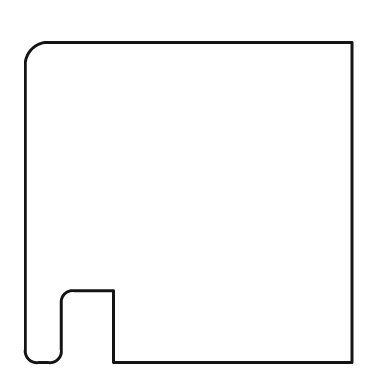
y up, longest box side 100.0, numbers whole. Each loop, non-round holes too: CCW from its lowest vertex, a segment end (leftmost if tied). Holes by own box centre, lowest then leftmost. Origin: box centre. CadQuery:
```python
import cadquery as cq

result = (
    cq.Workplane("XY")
    .moveTo(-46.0, -49.0)
    .lineTo(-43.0, -49.0)
    .threePointArc((-40.0, -48.0), (-39.0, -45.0))
    .lineTo(-39.0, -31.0)
    .threePointArc((-38.0, -28.0), (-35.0, -27.0))
    .lineTo(-23.0, -27.0)
    .lineTo(-23.0, -49.0)
    .lineTo(50.0, -49.0)
    .lineTo(50.0, 49.0)
    .lineTo(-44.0, 49.0)
    .threePointArc((-48.0, 47.0), (-50.0, 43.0))
    .lineTo(-50.0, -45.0)
    .threePointArc((-49.0, -48.0), (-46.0, -49.0))
    .close()
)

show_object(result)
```